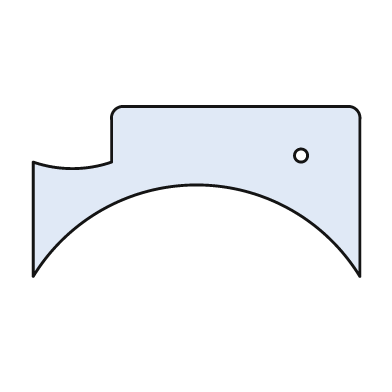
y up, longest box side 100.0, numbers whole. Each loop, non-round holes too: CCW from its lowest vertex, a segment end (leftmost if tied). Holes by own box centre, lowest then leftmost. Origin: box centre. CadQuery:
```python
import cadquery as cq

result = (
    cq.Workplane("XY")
    .moveTo(-50.0, -26.0)
    .threePointArc((0.0, 2.0), (50.0, -26.0))
    .lineTo(50.0, 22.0)
    .threePointArc((49.0, 25.0), (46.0, 26.0))
    .lineTo(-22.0, 26.0)
    .threePointArc((-25.0, 25.0), (-26.0, 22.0))
    .lineTo(-26.0, 9.0)
    .threePointArc((-38.0, 7.0), (-50.0, 9.0))
    .close()
    .moveTo(32.0, 11.0)
    .circle(2.0)
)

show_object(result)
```